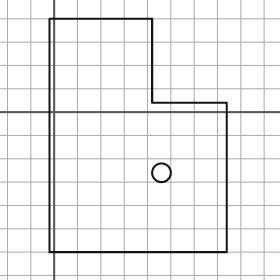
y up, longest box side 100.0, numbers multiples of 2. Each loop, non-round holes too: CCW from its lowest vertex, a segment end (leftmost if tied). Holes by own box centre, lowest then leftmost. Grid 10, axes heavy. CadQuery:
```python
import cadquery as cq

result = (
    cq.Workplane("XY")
    .moveTo(-2.0, -60.0)
    .lineTo(74.0, -60.0)
    .lineTo(74.0, 4.0)
    .lineTo(42.0, 4.0)
    .lineTo(42.0, 40.0)
    .lineTo(-2.0, 40.0)
    .close()
    .moveTo(46.0, -26.0)
    .circle(4.0)
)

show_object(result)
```